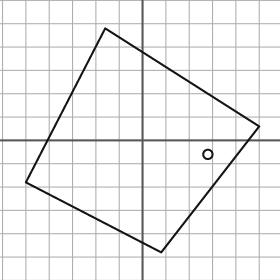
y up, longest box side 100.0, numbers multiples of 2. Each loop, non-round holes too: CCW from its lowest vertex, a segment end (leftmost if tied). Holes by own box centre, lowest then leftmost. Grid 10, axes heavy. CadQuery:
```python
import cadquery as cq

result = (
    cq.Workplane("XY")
    .moveTo(8.0, -48.0)
    .lineTo(50.0, 6.0)
    .lineTo(-16.0, 48.0)
    .lineTo(-50.0, -18.0)
    .close()
    .moveTo(28.0, -6.0)
    .circle(2.0)
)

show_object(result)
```